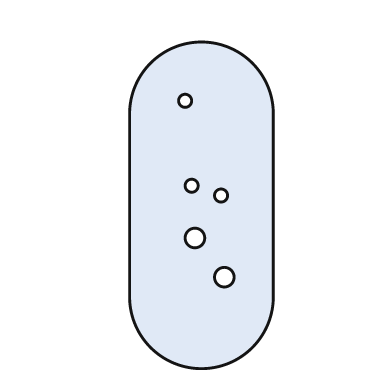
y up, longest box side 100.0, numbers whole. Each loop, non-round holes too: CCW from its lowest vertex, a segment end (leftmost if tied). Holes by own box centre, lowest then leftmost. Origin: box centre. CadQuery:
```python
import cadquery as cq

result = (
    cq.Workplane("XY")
    .moveTo(-22.0, -28.0)
    .threePointArc((0.0, -50.0), (22.0, -28.0))
    .lineTo(22.0, 28.0)
    .threePointArc((0.0, 50.0), (-22.0, 28.0))
    .close()
    .moveTo(7.0, -22.0)
    .circle(3.0)
    .moveTo(-2.0, -10.0)
    .circle(3.0)
    .moveTo(6.0, 3.0)
    .circle(2.0)
    .moveTo(-3.0, 6.0)
    .circle(2.0)
    .moveTo(-5.0, 32.0)
    .circle(2.0)
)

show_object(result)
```